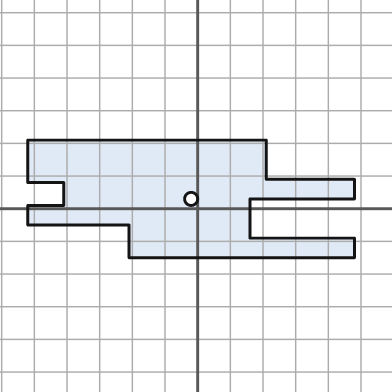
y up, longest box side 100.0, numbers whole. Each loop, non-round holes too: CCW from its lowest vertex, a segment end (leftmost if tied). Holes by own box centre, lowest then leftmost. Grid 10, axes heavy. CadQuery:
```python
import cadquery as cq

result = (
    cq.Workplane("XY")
    .moveTo(-21.0, -15.0)
    .lineTo(48.0, -15.0)
    .lineTo(48.0, -9.0)
    .lineTo(16.0, -9.0)
    .lineTo(16.0, 3.0)
    .lineTo(48.0, 3.0)
    .lineTo(48.0, 9.0)
    .lineTo(21.0, 9.0)
    .lineTo(21.0, 21.0)
    .lineTo(-52.0, 21.0)
    .lineTo(-52.0, 8.0)
    .lineTo(-41.0, 8.0)
    .lineTo(-41.0, 1.0)
    .lineTo(-52.0, 1.0)
    .lineTo(-52.0, -5.0)
    .lineTo(-21.0, -5.0)
    .close()
    .moveTo(-2.0, 3.0)
    .circle(2.0)
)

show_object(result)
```